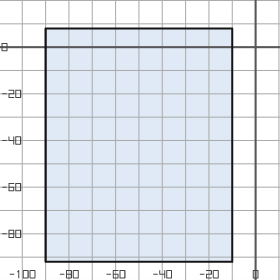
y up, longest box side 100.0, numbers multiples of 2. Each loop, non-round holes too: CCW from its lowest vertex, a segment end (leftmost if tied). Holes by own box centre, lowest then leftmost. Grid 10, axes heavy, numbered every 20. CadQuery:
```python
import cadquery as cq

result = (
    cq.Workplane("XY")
    .moveTo(-90.0, -92.0)
    .lineTo(-10.0, -92.0)
    .lineTo(-10.0, 8.0)
    .lineTo(-90.0, 8.0)
    .close()
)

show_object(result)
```